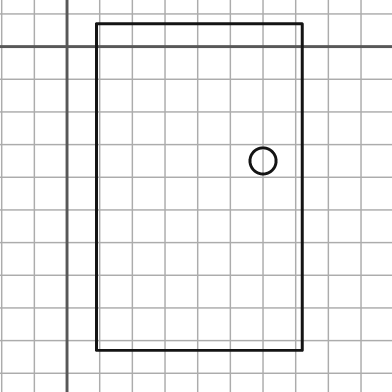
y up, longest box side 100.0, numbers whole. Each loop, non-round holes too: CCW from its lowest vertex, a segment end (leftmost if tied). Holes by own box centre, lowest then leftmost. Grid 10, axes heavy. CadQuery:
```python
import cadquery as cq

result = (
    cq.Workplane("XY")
    .moveTo(9.0, -93.0)
    .lineTo(72.0, -93.0)
    .lineTo(72.0, 7.0)
    .lineTo(9.0, 7.0)
    .close()
    .moveTo(60.0, -35.0)
    .circle(4.0)
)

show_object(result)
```